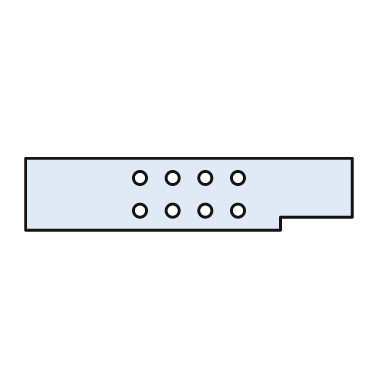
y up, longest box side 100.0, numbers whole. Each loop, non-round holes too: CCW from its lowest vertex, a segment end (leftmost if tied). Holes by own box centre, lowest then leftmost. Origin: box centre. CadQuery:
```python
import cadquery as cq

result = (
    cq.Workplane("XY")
    .moveTo(-50.0, -11.0)
    .lineTo(28.0, -11.0)
    .lineTo(28.0, -7.0)
    .lineTo(50.0, -7.0)
    .lineTo(50.0, 11.0)
    .lineTo(-50.0, 11.0)
    .close()
    .moveTo(-15.0, -5.0)
    .circle(2.0)
    .moveTo(-5.0, -5.0)
    .circle(2.0)
    .moveTo(5.0, -5.0)
    .circle(2.0)
    .moveTo(15.0, -5.0)
    .circle(2.0)
    .moveTo(-15.0, 5.0)
    .circle(2.0)
    .moveTo(-5.0, 5.0)
    .circle(2.0)
    .moveTo(5.0, 5.0)
    .circle(2.0)
    .moveTo(15.0, 5.0)
    .circle(2.0)
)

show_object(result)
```